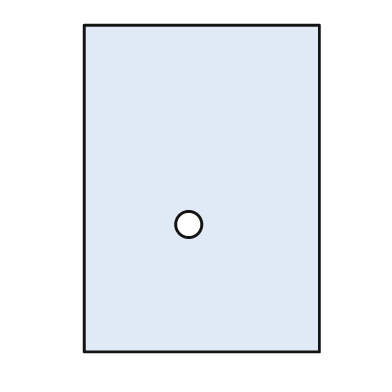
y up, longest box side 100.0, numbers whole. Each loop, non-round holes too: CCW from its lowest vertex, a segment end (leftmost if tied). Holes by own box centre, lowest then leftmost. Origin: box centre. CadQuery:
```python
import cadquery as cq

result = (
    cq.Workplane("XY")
    .moveTo(-36.0, -50.0)
    .lineTo(36.0, -50.0)
    .lineTo(36.0, 50.0)
    .lineTo(-36.0, 50.0)
    .close()
    .moveTo(-4.0, -11.0)
    .circle(4.0)
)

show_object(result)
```